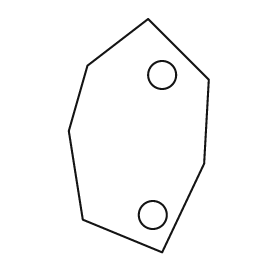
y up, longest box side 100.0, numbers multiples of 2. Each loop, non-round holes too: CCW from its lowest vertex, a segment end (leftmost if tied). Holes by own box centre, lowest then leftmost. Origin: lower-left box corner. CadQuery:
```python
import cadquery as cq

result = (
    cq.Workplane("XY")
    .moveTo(40.0, 0.0)
    .lineTo(58.0, 38.0)
    .lineTo(60.0, 74.0)
    .lineTo(34.0, 100.0)
    .lineTo(8.0, 80.0)
    .lineTo(0.0, 52.0)
    .lineTo(6.0, 14.0)
    .close()
    .moveTo(36.0, 16.0)
    .circle(6.0)
    .moveTo(40.0, 76.0)
    .circle(6.0)
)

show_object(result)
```